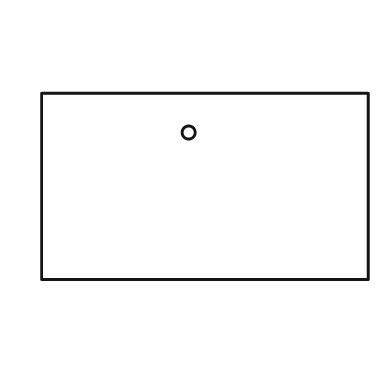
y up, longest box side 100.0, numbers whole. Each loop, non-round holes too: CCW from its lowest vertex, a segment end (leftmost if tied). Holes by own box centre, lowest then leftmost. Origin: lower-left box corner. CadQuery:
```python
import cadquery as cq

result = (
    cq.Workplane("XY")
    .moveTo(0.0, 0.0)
    .lineTo(100.0, 0.0)
    .lineTo(100.0, 57.0)
    .lineTo(0.0, 57.0)
    .close()
    .moveTo(45.0, 45.0)
    .circle(2.0)
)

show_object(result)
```